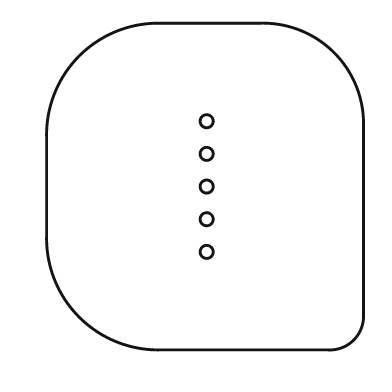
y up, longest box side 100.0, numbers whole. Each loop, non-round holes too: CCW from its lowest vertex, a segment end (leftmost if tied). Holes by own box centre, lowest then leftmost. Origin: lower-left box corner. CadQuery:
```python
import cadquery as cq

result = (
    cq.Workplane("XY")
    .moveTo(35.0, 0.0)
    .lineTo(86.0, 0.0)
    .threePointArc((94.0, 3.0), (97.0, 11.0))
    .lineTo(97.0, 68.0)
    .threePointArc((88.0, 91.0), (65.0, 100.0))
    .lineTo(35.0, 100.0)
    .threePointArc((10.0, 90.0), (0.0, 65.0))
    .lineTo(0.0, 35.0)
    .threePointArc((10.0, 10.0), (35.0, 0.0))
    .close()
    .moveTo(49.0, 30.0)
    .circle(2.0)
    .moveTo(49.0, 40.0)
    .circle(2.0)
    .moveTo(49.0, 50.0)
    .circle(2.0)
    .moveTo(49.0, 60.0)
    .circle(2.0)
    .moveTo(49.0, 70.0)
    .circle(2.0)
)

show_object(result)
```